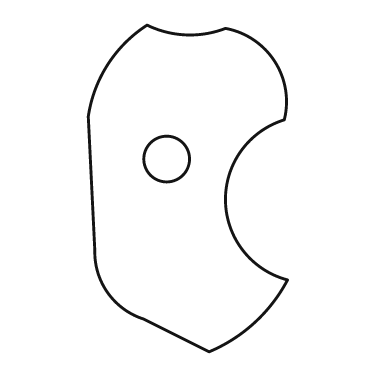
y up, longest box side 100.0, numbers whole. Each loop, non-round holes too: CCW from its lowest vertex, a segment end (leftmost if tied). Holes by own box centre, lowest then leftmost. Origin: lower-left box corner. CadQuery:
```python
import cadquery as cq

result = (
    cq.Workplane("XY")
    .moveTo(37.0, 0.0)
    .threePointArc((51.0, 9.0), (61.0, 22.0))
    .threePointArc((42.0, 46.0), (60.0, 71.0))
    .threePointArc((57.0, 89.0), (42.0, 99.0))
    .threePointArc((30.0, 97.0), (18.0, 100.0))
    .threePointArc((6.0, 88.0), (0.0, 72.0))
    .lineTo(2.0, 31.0)
    .threePointArc((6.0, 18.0), (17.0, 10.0))
    .close()
    .moveTo(24.0, 59.0)
    .circle(7.0)
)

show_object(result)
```